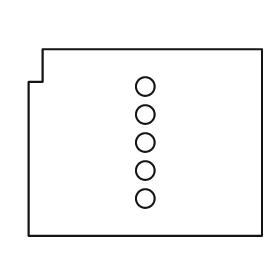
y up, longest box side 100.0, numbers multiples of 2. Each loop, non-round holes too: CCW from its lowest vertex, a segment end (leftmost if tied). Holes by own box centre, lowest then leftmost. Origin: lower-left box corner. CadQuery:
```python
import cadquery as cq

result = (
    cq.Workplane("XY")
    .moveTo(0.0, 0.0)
    .lineTo(100.0, 0.0)
    .lineTo(100.0, 80.0)
    .lineTo(6.0, 80.0)
    .lineTo(6.0, 66.0)
    .lineTo(0.0, 66.0)
    .close()
    .moveTo(50.0, 16.0)
    .circle(4.0)
    .moveTo(50.0, 28.0)
    .circle(4.0)
    .moveTo(50.0, 40.0)
    .circle(4.0)
    .moveTo(50.0, 52.0)
    .circle(4.0)
    .moveTo(50.0, 64.0)
    .circle(4.0)
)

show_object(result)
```